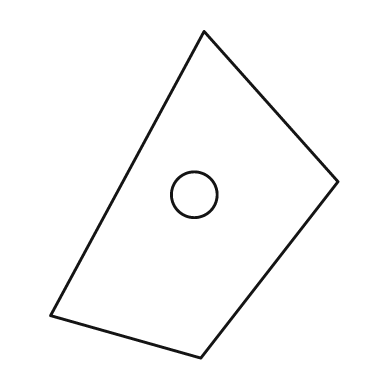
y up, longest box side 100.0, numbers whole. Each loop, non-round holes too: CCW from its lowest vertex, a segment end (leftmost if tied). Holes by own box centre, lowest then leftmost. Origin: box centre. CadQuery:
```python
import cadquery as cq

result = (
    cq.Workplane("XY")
    .moveTo(2.0, -50.0)
    .lineTo(44.0, 4.0)
    .lineTo(3.0, 50.0)
    .lineTo(-44.0, -37.0)
    .close()
    .moveTo(0.0, 0.0)
    .circle(7.0)
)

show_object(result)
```